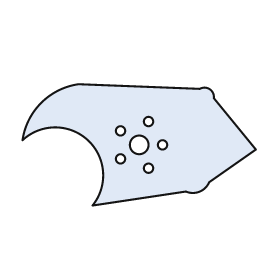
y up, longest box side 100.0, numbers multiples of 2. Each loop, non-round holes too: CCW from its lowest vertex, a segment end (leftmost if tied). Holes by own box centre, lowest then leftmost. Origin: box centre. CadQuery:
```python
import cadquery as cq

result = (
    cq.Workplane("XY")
    .moveTo(-20.0, -26.0)
    .lineTo(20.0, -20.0)
    .threePointArc((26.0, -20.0), (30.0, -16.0))
    .lineTo(50.0, -2.0)
    .lineTo(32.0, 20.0)
    .threePointArc((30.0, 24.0), (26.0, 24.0))
    .lineTo(-26.0, 26.0)
    .threePointArc((-42.0, 18.0), (-50.0, 2.0))
    .threePointArc((-22.0, 2.0), (-20.0, -26.0))
    .close()
    .moveTo(4.0, -10.0)
    .circle(2.0)
    .moveTo(-8.0, -6.0)
    .circle(2.0)
    .moveTo(0.0, 0.0)
    .circle(4.0)
    .moveTo(10.0, 0.0)
    .circle(2.0)
    .moveTo(-8.0, 6.0)
    .circle(2.0)
    .moveTo(4.0, 10.0)
    .circle(2.0)
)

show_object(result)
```